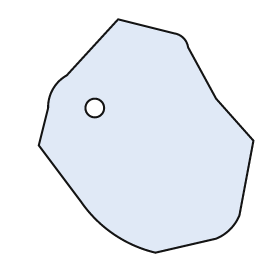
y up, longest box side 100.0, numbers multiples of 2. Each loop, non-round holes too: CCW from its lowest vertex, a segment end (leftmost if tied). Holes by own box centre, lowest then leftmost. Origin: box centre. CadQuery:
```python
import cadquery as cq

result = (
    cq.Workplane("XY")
    .moveTo(4.0, -50.0)
    .lineTo(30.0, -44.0)
    .threePointArc((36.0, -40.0), (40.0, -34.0))
    .lineTo(46.0, -2.0)
    .lineTo(30.0, 16.0)
    .lineTo(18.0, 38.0)
    .threePointArc((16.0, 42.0), (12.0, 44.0))
    .lineTo(-12.0, 50.0)
    .lineTo(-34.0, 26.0)
    .threePointArc((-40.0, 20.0), (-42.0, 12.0))
    .lineTo(-46.0, -4.0)
    .lineTo(-28.0, -28.0)
    .threePointArc((-14.0, -42.0), (4.0, -50.0))
    .close()
    .moveTo(-22.0, 12.0)
    .circle(4.0)
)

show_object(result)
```